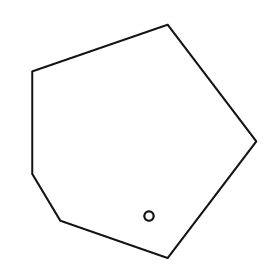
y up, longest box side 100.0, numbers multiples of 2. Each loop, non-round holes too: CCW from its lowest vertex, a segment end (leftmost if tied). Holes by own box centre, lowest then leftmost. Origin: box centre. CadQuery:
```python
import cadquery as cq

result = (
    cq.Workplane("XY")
    .moveTo(10.0, -50.0)
    .lineTo(48.0, 0.0)
    .lineTo(10.0, 50.0)
    .lineTo(-48.0, 30.0)
    .lineTo(-48.0, -14.0)
    .lineTo(-36.0, -34.0)
    .close()
    .moveTo(2.0, -32.0)
    .circle(2.0)
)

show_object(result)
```